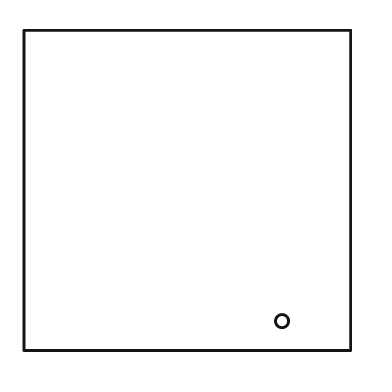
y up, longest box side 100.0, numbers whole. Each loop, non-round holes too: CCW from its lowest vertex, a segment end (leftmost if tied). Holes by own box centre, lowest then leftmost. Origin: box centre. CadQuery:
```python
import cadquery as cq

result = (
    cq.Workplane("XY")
    .moveTo(-50.0, -49.0)
    .lineTo(50.0, -49.0)
    .lineTo(50.0, 49.0)
    .lineTo(-50.0, 49.0)
    .close()
    .moveTo(29.0, -40.0)
    .circle(2.0)
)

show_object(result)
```